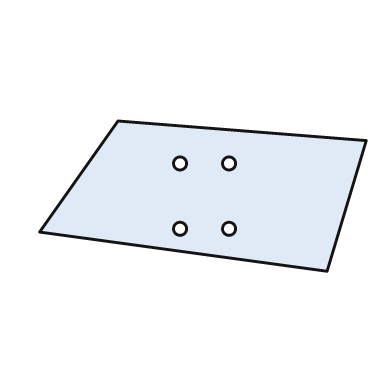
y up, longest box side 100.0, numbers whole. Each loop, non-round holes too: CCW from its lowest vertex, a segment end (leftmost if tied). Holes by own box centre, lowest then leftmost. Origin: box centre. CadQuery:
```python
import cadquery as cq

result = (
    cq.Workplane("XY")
    .moveTo(38.0, -23.0)
    .lineTo(50.0, 17.0)
    .lineTo(-26.0, 23.0)
    .lineTo(-50.0, -11.0)
    .close()
    .moveTo(-7.0, -10.0)
    .circle(2.0)
    .moveTo(8.0, -10.0)
    .circle(2.0)
    .moveTo(-7.0, 10.0)
    .circle(2.0)
    .moveTo(8.0, 10.0)
    .circle(2.0)
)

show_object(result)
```